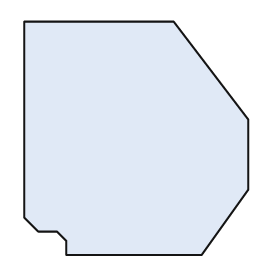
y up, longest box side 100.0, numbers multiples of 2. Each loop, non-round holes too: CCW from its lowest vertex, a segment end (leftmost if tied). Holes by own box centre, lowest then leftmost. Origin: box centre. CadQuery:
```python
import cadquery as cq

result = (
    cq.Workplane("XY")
    .moveTo(-30.0, -50.0)
    .lineTo(28.0, -50.0)
    .lineTo(48.0, -22.0)
    .lineTo(48.0, 8.0)
    .lineTo(16.0, 50.0)
    .lineTo(-48.0, 50.0)
    .lineTo(-48.0, -34.0)
    .lineTo(-42.0, -40.0)
    .lineTo(-34.0, -40.0)
    .lineTo(-30.0, -44.0)
    .close()
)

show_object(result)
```